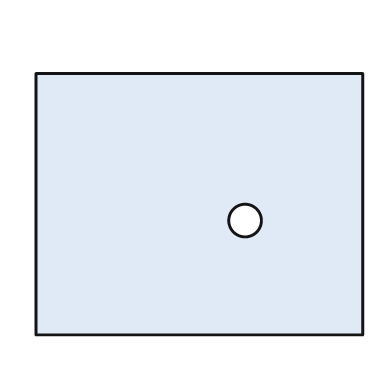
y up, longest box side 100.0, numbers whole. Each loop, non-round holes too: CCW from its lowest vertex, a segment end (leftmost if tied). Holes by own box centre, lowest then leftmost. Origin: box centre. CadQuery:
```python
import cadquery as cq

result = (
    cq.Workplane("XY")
    .moveTo(-50.0, -40.0)
    .lineTo(50.0, -40.0)
    .lineTo(50.0, 40.0)
    .lineTo(-50.0, 40.0)
    .close()
    .moveTo(14.0, -5.0)
    .circle(5.0)
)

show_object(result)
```